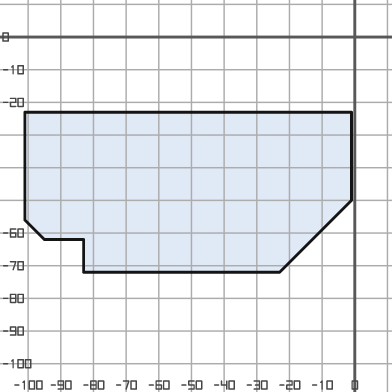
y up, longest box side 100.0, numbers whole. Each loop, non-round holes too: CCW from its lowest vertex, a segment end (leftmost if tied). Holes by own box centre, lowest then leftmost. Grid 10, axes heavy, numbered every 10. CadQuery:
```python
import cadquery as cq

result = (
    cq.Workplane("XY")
    .moveTo(-83.0, -72.0)
    .lineTo(-23.0, -72.0)
    .lineTo(-1.0, -50.0)
    .lineTo(-1.0, -23.0)
    .lineTo(-101.0, -23.0)
    .lineTo(-101.0, -56.0)
    .lineTo(-95.0, -62.0)
    .lineTo(-83.0, -62.0)
    .close()
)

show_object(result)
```